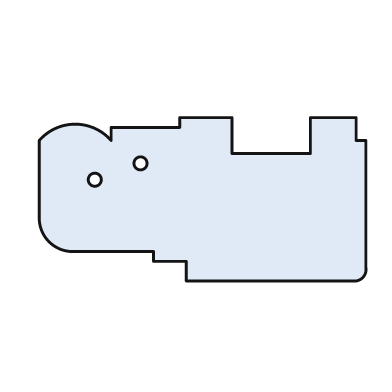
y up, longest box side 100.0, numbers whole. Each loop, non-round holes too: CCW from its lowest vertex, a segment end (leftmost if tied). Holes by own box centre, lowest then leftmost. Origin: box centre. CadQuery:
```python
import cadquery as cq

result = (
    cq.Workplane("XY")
    .moveTo(-5.0, -25.0)
    .lineTo(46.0, -25.0)
    .threePointArc((49.0, -24.0), (50.0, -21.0))
    .lineTo(50.0, 18.0)
    .lineTo(47.0, 18.0)
    .lineTo(47.0, 25.0)
    .lineTo(33.0, 25.0)
    .lineTo(33.0, 14.0)
    .lineTo(9.0, 14.0)
    .lineTo(9.0, 25.0)
    .lineTo(-7.0, 25.0)
    .lineTo(-7.0, 22.0)
    .lineTo(-28.0, 22.0)
    .lineTo(-28.0, 18.0)
    .threePointArc((-39.0, 23.0), (-50.0, 18.0))
    .lineTo(-50.0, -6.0)
    .threePointArc((-47.0, -13.0), (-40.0, -16.0))
    .lineTo(-15.0, -16.0)
    .lineTo(-15.0, -19.0)
    .lineTo(-5.0, -19.0)
    .close()
    .moveTo(-33.0, 6.0)
    .circle(2.0)
    .moveTo(-19.0, 11.0)
    .circle(2.0)
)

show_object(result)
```